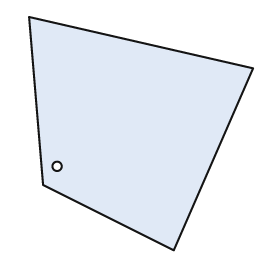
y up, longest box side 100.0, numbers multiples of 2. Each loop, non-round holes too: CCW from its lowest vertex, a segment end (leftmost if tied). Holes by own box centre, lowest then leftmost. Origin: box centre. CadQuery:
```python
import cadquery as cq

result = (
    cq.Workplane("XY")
    .moveTo(14.0, -50.0)
    .lineTo(48.0, 28.0)
    .lineTo(-48.0, 50.0)
    .lineTo(-42.0, -22.0)
    .close()
    .moveTo(-36.0, -14.0)
    .circle(2.0)
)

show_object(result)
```